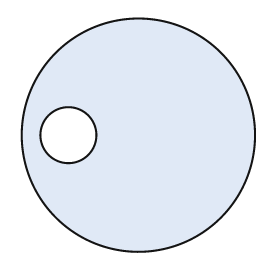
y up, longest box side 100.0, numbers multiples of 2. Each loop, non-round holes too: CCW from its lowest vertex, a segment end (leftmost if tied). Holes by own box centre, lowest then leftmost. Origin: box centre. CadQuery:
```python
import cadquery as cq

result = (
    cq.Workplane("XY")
    .moveTo(0.0, 0.0)
    .circle(50.0)
    .moveTo(-30.0, 0.0)
    .circle(12.0)
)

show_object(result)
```